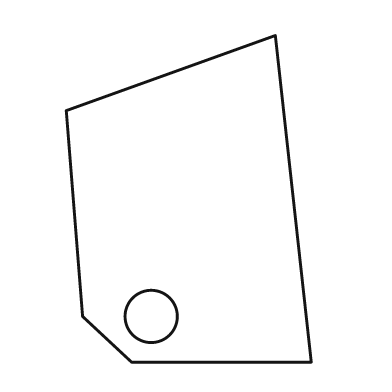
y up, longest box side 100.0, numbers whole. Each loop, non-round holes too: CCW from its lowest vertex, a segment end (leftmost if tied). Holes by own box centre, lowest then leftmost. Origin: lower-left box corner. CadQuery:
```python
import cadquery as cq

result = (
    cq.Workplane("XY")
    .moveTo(20.0, 0.0)
    .lineTo(75.0, 0.0)
    .lineTo(64.0, 100.0)
    .lineTo(0.0, 77.0)
    .lineTo(5.0, 14.0)
    .close()
    .moveTo(26.0, 14.0)
    .circle(8.0)
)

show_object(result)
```